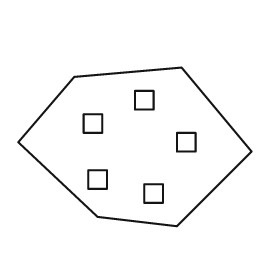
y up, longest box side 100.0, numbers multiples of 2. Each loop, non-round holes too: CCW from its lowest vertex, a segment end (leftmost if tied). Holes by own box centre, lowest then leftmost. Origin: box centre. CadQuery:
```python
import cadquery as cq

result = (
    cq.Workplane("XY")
    .moveTo(18.0, -34.0)
    .lineTo(50.0, -2.0)
    .lineTo(20.0, 34.0)
    .lineTo(-26.0, 30.0)
    .lineTo(-50.0, 2.0)
    .lineTo(-16.0, -30.0)
    .close()
    .moveTo(4.0, -24.0)
    .lineTo(12.0, -24.0)
    .lineTo(12.0, -16.0)
    .lineTo(4.0, -16.0)
    .close()
    .moveTo(-20.0, -18.0)
    .lineTo(-12.0, -18.0)
    .lineTo(-12.0, -10.0)
    .lineTo(-20.0, -10.0)
    .close()
    .moveTo(18.0, -2.0)
    .lineTo(26.0, -2.0)
    .lineTo(26.0, 6.0)
    .lineTo(18.0, 6.0)
    .close()
    .moveTo(-22.0, 6.0)
    .lineTo(-14.0, 6.0)
    .lineTo(-14.0, 14.0)
    .lineTo(-22.0, 14.0)
    .close()
    .moveTo(0.0, 16.0)
    .lineTo(8.0, 16.0)
    .lineTo(8.0, 24.0)
    .lineTo(0.0, 24.0)
    .close()
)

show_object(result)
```